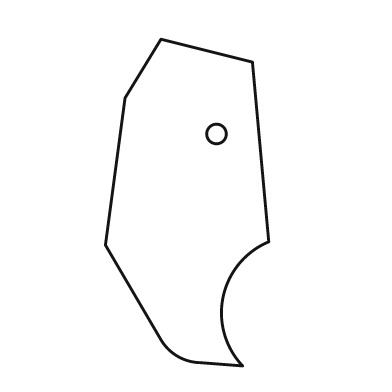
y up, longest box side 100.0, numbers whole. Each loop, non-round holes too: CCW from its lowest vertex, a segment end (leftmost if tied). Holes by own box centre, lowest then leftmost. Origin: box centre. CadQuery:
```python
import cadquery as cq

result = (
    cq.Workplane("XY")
    .moveTo(17.0, -50.0)
    .threePointArc((11.0, -29.0), (25.0, -12.0))
    .lineTo(20.0, 43.0)
    .lineTo(-8.0, 50.0)
    .lineTo(-19.0, 32.0)
    .lineTo(-25.0, -13.0)
    .lineTo(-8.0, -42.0)
    .threePointArc((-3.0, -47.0), (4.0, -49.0))
    .close()
    .moveTo(9.0, 21.0)
    .circle(3.0)
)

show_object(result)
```